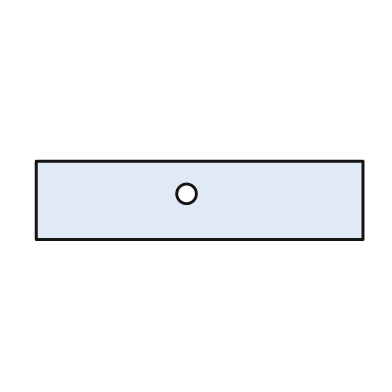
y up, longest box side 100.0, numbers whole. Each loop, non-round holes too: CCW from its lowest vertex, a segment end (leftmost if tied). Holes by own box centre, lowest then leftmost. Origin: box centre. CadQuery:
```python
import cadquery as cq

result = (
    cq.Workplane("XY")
    .moveTo(-50.0, -12.0)
    .lineTo(50.0, -12.0)
    .lineTo(50.0, 12.0)
    .lineTo(-50.0, 12.0)
    .close()
    .moveTo(-4.0, 2.0)
    .circle(3.0)
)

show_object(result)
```